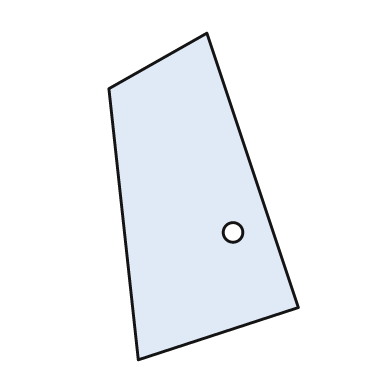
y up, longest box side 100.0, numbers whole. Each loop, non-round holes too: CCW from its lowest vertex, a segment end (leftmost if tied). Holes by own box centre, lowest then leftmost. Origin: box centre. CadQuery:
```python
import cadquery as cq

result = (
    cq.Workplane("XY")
    .moveTo(-20.0, -50.0)
    .lineTo(29.0, -34.0)
    .lineTo(1.0, 50.0)
    .lineTo(-29.0, 33.0)
    .close()
    .moveTo(9.0, -11.0)
    .circle(3.0)
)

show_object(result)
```